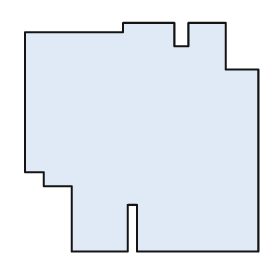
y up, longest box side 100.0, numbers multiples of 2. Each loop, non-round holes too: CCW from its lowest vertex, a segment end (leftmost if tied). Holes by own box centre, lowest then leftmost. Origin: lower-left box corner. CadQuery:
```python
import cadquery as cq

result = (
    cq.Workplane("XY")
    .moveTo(20.0, 0.0)
    .lineTo(44.0, 0.0)
    .lineTo(44.0, 20.0)
    .lineTo(48.0, 20.0)
    .lineTo(48.0, 0.0)
    .lineTo(100.0, 0.0)
    .lineTo(100.0, 78.0)
    .lineTo(86.0, 78.0)
    .lineTo(86.0, 98.0)
    .lineTo(70.0, 98.0)
    .lineTo(70.0, 88.0)
    .lineTo(64.0, 88.0)
    .lineTo(64.0, 98.0)
    .lineTo(42.0, 98.0)
    .lineTo(42.0, 94.0)
    .lineTo(0.0, 94.0)
    .lineTo(0.0, 34.0)
    .lineTo(8.0, 34.0)
    .lineTo(8.0, 28.0)
    .lineTo(20.0, 28.0)
    .close()
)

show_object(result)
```